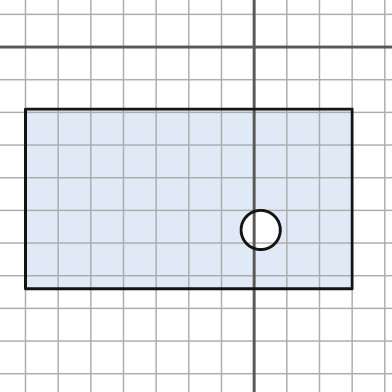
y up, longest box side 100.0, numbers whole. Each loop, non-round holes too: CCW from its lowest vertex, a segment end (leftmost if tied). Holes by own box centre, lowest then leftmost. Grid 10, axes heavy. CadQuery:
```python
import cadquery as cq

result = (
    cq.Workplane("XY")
    .moveTo(-70.0, -74.0)
    .lineTo(30.0, -74.0)
    .lineTo(30.0, -19.0)
    .lineTo(-70.0, -19.0)
    .close()
    .moveTo(2.0, -56.0)
    .circle(6.0)
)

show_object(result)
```